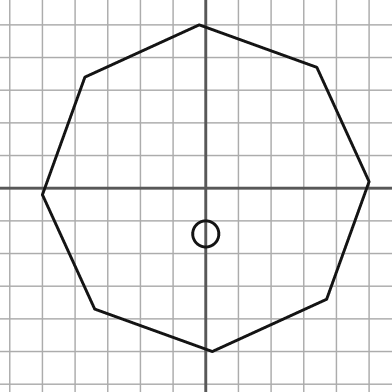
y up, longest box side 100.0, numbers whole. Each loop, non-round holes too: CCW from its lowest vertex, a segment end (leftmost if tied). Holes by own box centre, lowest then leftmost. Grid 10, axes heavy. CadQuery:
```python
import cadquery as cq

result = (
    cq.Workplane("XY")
    .moveTo(2.0, -50.0)
    .lineTo(37.0, -34.0)
    .lineTo(50.0, 2.0)
    .lineTo(34.0, 37.0)
    .lineTo(-2.0, 50.0)
    .lineTo(-37.0, 34.0)
    .lineTo(-50.0, -2.0)
    .lineTo(-34.0, -37.0)
    .close()
    .moveTo(0.0, -14.0)
    .circle(4.0)
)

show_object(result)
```